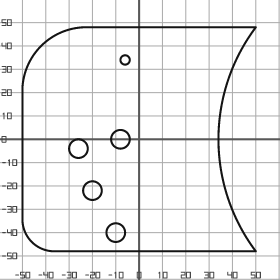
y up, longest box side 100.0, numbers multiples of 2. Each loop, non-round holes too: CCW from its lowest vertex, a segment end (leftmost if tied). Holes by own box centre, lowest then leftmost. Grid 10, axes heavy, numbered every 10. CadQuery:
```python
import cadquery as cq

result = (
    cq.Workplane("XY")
    .moveTo(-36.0, -48.0)
    .lineTo(50.0, -48.0)
    .threePointArc((34.0, 0.0), (50.0, 48.0))
    .lineTo(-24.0, 48.0)
    .threePointArc((-42.0, 40.0), (-50.0, 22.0))
    .lineTo(-50.0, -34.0)
    .threePointArc((-46.0, -44.0), (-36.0, -48.0))
    .close()
    .moveTo(-10.0, -40.0)
    .circle(4.0)
    .moveTo(-20.0, -22.0)
    .circle(4.0)
    .moveTo(-26.0, -4.0)
    .circle(4.0)
    .moveTo(-8.0, 0.0)
    .circle(4.0)
    .moveTo(-6.0, 34.0)
    .circle(2.0)
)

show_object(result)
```